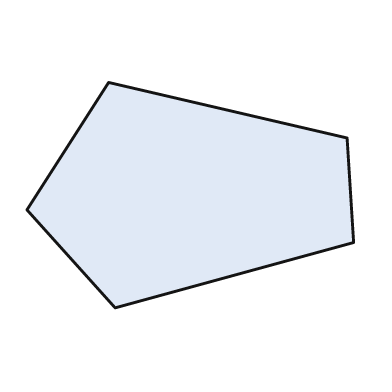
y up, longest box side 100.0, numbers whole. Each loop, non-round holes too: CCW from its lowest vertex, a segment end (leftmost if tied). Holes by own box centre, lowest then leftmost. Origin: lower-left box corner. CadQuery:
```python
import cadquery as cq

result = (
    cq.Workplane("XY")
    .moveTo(27.0, 0.0)
    .lineTo(100.0, 20.0)
    .lineTo(98.0, 52.0)
    .lineTo(25.0, 69.0)
    .lineTo(0.0, 30.0)
    .close()
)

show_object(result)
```